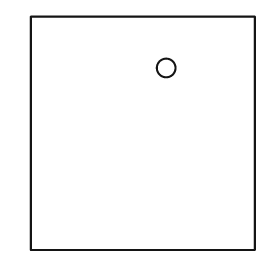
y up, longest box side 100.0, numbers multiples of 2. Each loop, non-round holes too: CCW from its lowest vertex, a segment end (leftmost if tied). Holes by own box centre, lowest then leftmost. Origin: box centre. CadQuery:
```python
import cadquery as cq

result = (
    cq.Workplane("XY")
    .moveTo(-48.0, -50.0)
    .lineTo(48.0, -50.0)
    .lineTo(48.0, 50.0)
    .lineTo(-48.0, 50.0)
    .close()
    .moveTo(10.0, 28.0)
    .circle(4.0)
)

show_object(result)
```